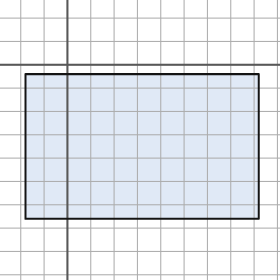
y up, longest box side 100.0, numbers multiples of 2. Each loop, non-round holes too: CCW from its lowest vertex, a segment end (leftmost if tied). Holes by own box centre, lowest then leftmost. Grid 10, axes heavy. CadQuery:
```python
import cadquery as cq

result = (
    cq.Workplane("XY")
    .moveTo(-18.0, -66.0)
    .lineTo(82.0, -66.0)
    .lineTo(82.0, -4.0)
    .lineTo(-18.0, -4.0)
    .close()
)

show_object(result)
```